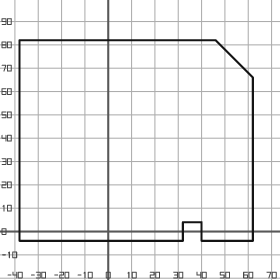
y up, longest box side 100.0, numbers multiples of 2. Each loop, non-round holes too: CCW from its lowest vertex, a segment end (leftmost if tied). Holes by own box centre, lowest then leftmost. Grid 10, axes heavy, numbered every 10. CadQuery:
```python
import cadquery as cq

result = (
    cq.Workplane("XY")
    .moveTo(-38.0, -4.0)
    .lineTo(32.0, -4.0)
    .lineTo(32.0, 4.0)
    .lineTo(40.0, 4.0)
    .lineTo(40.0, -4.0)
    .lineTo(62.0, -4.0)
    .lineTo(62.0, 66.0)
    .lineTo(46.0, 82.0)
    .lineTo(-38.0, 82.0)
    .close()
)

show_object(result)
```